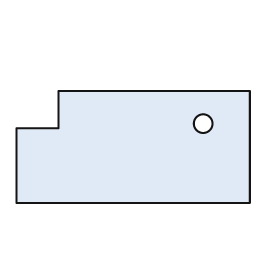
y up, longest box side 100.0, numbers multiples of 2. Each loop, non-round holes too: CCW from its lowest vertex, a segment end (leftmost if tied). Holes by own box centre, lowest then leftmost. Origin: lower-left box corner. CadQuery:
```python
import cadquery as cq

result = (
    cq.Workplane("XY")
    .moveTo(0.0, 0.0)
    .lineTo(100.0, 0.0)
    .lineTo(100.0, 48.0)
    .lineTo(18.0, 48.0)
    .lineTo(18.0, 32.0)
    .lineTo(0.0, 32.0)
    .close()
    .moveTo(80.0, 34.0)
    .circle(4.0)
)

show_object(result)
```